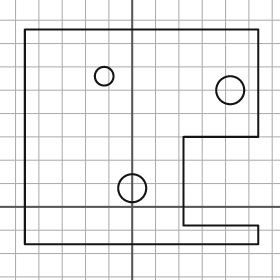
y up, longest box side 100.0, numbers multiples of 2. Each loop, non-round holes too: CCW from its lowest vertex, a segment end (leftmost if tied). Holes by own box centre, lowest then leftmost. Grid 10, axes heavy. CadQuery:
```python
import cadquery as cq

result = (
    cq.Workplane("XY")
    .moveTo(-46.0, -16.0)
    .lineTo(54.0, -16.0)
    .lineTo(54.0, -8.0)
    .lineTo(22.0, -8.0)
    .lineTo(22.0, 30.0)
    .lineTo(54.0, 30.0)
    .lineTo(54.0, 76.0)
    .lineTo(-46.0, 76.0)
    .close()
    .moveTo(0.0, 8.0)
    .circle(6.0)
    .moveTo(42.0, 50.0)
    .circle(6.0)
    .moveTo(-12.0, 56.0)
    .circle(4.0)
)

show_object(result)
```